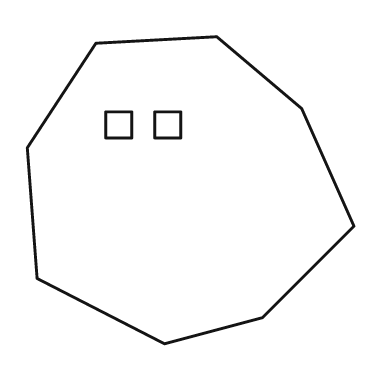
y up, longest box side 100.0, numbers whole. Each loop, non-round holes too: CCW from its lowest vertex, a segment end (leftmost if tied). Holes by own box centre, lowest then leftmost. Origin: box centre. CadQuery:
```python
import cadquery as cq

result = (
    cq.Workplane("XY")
    .moveTo(-8.0, -47.0)
    .lineTo(22.0, -39.0)
    .lineTo(50.0, -11.0)
    .lineTo(34.0, 25.0)
    .lineTo(8.0, 47.0)
    .lineTo(-29.0, 45.0)
    .lineTo(-50.0, 13.0)
    .lineTo(-47.0, -27.0)
    .close()
    .moveTo(-26.0, 16.0)
    .lineTo(-18.0, 16.0)
    .lineTo(-18.0, 24.0)
    .lineTo(-26.0, 24.0)
    .close()
    .moveTo(-11.0, 16.0)
    .lineTo(-3.0, 16.0)
    .lineTo(-3.0, 24.0)
    .lineTo(-11.0, 24.0)
    .close()
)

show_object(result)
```